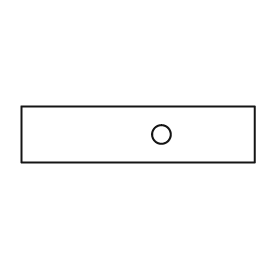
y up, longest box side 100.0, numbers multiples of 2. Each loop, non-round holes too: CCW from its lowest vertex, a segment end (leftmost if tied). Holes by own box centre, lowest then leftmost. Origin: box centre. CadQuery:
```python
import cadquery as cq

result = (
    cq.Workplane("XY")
    .moveTo(-50.0, -12.0)
    .lineTo(50.0, -12.0)
    .lineTo(50.0, 12.0)
    .lineTo(-50.0, 12.0)
    .close()
    .moveTo(10.0, 0.0)
    .circle(4.0)
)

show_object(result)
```